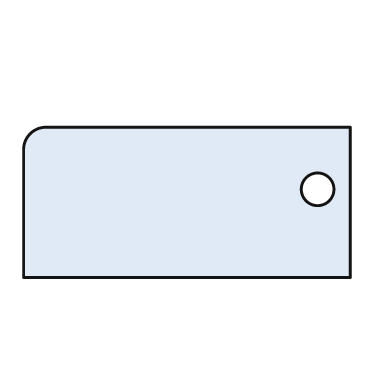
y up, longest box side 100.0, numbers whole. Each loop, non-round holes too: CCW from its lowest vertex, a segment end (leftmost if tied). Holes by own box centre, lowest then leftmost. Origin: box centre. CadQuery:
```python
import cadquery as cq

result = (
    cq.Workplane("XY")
    .moveTo(-50.0, -23.0)
    .lineTo(50.0, -23.0)
    .lineTo(50.0, 23.0)
    .lineTo(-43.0, 23.0)
    .threePointArc((-48.0, 21.0), (-50.0, 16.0))
    .close()
    .moveTo(40.0, 4.0)
    .circle(5.0)
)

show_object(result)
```